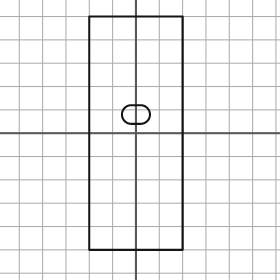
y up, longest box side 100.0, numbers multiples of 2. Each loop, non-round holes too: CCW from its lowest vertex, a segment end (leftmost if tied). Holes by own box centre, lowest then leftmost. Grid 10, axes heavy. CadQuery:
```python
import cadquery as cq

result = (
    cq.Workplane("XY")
    .moveTo(-20.0, -50.0)
    .lineTo(20.0, -50.0)
    .lineTo(20.0, 50.0)
    .lineTo(-20.0, 50.0)
    .close()
    .moveTo(-2.0, 4.0)
    .lineTo(2.0, 4.0)
    .threePointArc((6.0, 8.0), (2.0, 12.0))
    .lineTo(-2.0, 12.0)
    .threePointArc((-6.0, 8.0), (-2.0, 4.0))
    .close()
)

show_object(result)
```